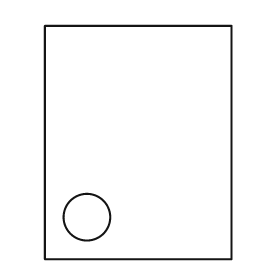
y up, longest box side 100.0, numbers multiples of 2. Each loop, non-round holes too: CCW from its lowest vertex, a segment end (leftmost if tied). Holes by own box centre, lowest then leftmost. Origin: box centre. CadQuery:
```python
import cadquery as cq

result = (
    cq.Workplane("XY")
    .moveTo(-40.0, -50.0)
    .lineTo(40.0, -50.0)
    .lineTo(40.0, 50.0)
    .lineTo(-40.0, 50.0)
    .close()
    .moveTo(-22.0, -32.0)
    .circle(10.0)
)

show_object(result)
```